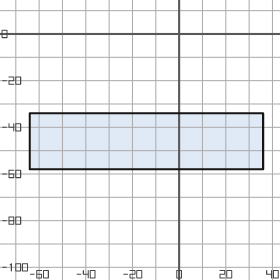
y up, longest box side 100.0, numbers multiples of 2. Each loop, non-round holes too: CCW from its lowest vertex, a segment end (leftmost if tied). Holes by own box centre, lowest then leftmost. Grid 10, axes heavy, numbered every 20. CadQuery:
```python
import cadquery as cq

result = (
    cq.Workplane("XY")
    .moveTo(-64.0, -58.0)
    .lineTo(36.0, -58.0)
    .lineTo(36.0, -34.0)
    .lineTo(-64.0, -34.0)
    .close()
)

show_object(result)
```